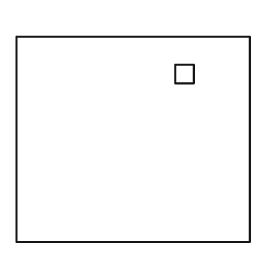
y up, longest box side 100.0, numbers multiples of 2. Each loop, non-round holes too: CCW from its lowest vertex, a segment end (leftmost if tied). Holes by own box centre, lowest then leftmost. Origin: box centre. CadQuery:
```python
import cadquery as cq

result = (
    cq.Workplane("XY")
    .moveTo(-50.0, -44.0)
    .lineTo(50.0, -44.0)
    .lineTo(50.0, 44.0)
    .lineTo(-50.0, 44.0)
    .close()
    .moveTo(18.0, 24.0)
    .lineTo(26.0, 24.0)
    .lineTo(26.0, 32.0)
    .lineTo(18.0, 32.0)
    .close()
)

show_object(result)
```